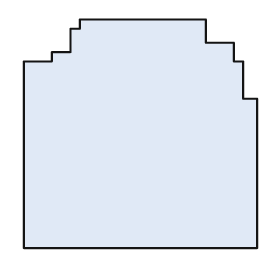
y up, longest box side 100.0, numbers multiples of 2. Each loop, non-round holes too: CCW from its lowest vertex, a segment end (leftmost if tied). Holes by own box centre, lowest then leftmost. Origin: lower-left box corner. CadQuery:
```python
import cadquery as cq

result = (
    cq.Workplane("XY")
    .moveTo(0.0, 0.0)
    .lineTo(100.0, 0.0)
    .lineTo(100.0, 64.0)
    .lineTo(94.0, 64.0)
    .lineTo(94.0, 80.0)
    .lineTo(90.0, 80.0)
    .lineTo(90.0, 88.0)
    .lineTo(78.0, 88.0)
    .lineTo(78.0, 98.0)
    .lineTo(24.0, 98.0)
    .lineTo(24.0, 94.0)
    .lineTo(20.0, 94.0)
    .lineTo(20.0, 84.0)
    .lineTo(12.0, 84.0)
    .lineTo(12.0, 80.0)
    .lineTo(0.0, 80.0)
    .close()
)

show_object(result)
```